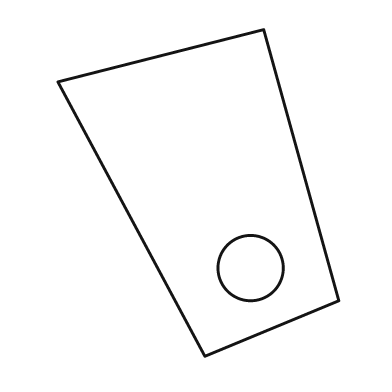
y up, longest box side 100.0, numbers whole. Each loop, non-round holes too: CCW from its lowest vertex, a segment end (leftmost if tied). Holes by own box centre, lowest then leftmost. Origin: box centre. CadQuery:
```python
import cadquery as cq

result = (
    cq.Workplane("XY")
    .moveTo(2.0, -50.0)
    .lineTo(43.0, -33.0)
    .lineTo(20.0, 50.0)
    .lineTo(-43.0, 34.0)
    .close()
    .moveTo(16.0, -23.0)
    .circle(10.0)
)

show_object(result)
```